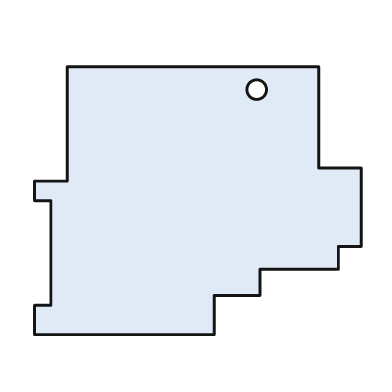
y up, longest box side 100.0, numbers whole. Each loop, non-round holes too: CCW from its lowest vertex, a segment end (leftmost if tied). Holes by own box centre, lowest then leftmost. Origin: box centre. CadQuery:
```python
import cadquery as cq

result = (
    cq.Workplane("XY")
    .moveTo(-50.0, -41.0)
    .lineTo(5.0, -41.0)
    .lineTo(5.0, -29.0)
    .lineTo(19.0, -29.0)
    .lineTo(19.0, -21.0)
    .lineTo(43.0, -21.0)
    .lineTo(43.0, -14.0)
    .lineTo(50.0, -14.0)
    .lineTo(50.0, 10.0)
    .lineTo(37.0, 10.0)
    .lineTo(37.0, 41.0)
    .lineTo(-40.0, 41.0)
    .lineTo(-40.0, 6.0)
    .lineTo(-50.0, 6.0)
    .lineTo(-50.0, 0.0)
    .lineTo(-45.0, 0.0)
    .lineTo(-45.0, -32.0)
    .lineTo(-50.0, -32.0)
    .close()
    .moveTo(18.0, 34.0)
    .circle(3.0)
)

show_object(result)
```